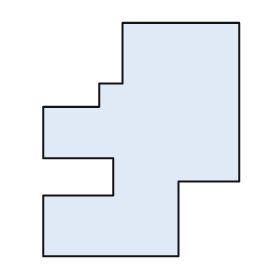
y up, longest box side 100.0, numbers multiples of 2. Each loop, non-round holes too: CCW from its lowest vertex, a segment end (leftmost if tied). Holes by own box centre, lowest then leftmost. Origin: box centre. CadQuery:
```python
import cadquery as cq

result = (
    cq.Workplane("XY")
    .moveTo(-42.0, -50.0)
    .lineTo(16.0, -50.0)
    .lineTo(16.0, -18.0)
    .lineTo(42.0, -18.0)
    .lineTo(42.0, 50.0)
    .lineTo(-8.0, 50.0)
    .lineTo(-8.0, 24.0)
    .lineTo(-18.0, 24.0)
    .lineTo(-18.0, 14.0)
    .lineTo(-42.0, 14.0)
    .lineTo(-42.0, -8.0)
    .lineTo(-12.0, -8.0)
    .lineTo(-12.0, -24.0)
    .lineTo(-42.0, -24.0)
    .close()
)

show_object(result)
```